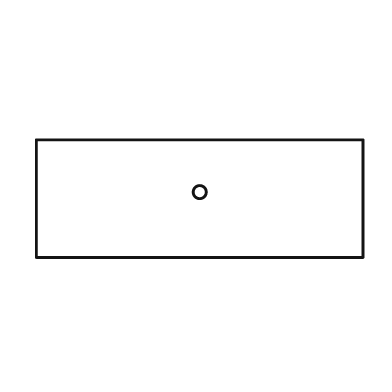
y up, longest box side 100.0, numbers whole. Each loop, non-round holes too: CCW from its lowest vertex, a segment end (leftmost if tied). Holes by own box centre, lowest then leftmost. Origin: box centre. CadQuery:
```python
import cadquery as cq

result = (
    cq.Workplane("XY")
    .moveTo(-50.0, -18.0)
    .lineTo(50.0, -18.0)
    .lineTo(50.0, 18.0)
    .lineTo(-50.0, 18.0)
    .close()
    .moveTo(0.0, 2.0)
    .circle(2.0)
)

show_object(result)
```